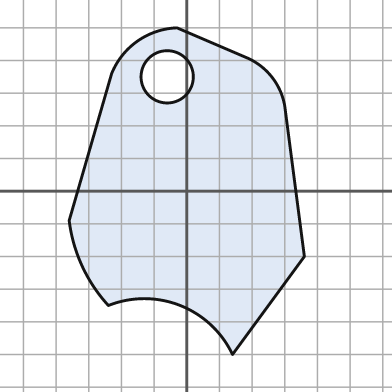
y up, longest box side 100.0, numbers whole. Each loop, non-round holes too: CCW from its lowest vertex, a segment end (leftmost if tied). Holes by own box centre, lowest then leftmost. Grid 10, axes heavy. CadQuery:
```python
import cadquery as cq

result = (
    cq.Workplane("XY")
    .moveTo(14.0, -50.0)
    .lineTo(36.0, -20.0)
    .lineTo(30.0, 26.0)
    .threePointArc((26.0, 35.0), (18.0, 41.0))
    .lineTo(-3.0, 50.0)
    .threePointArc((-15.0, 46.0), (-23.0, 36.0))
    .lineTo(-36.0, -9.0)
    .threePointArc((-32.0, -23.0), (-24.0, -35.0))
    .threePointArc((-2.0, -35.0), (14.0, -50.0))
    .close()
    .moveTo(-6.0, 35.0)
    .circle(8.0)
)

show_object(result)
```